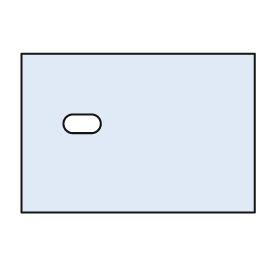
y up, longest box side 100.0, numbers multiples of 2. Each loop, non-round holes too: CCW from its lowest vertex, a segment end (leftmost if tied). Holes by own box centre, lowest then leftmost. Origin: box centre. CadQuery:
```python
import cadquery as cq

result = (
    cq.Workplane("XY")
    .moveTo(-50.0, -34.0)
    .lineTo(50.0, -34.0)
    .lineTo(50.0, 34.0)
    .lineTo(-50.0, 34.0)
    .close()
    .moveTo(-28.0, 0.0)
    .lineTo(-20.0, 0.0)
    .threePointArc((-16.0, 4.0), (-20.0, 8.0))
    .lineTo(-28.0, 8.0)
    .threePointArc((-32.0, 4.0), (-28.0, 0.0))
    .close()
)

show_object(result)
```